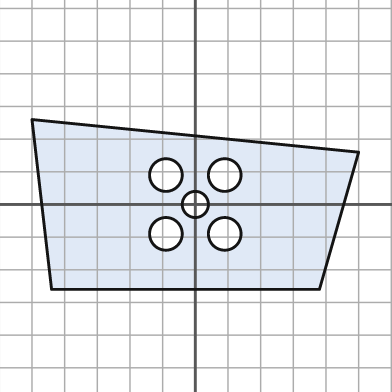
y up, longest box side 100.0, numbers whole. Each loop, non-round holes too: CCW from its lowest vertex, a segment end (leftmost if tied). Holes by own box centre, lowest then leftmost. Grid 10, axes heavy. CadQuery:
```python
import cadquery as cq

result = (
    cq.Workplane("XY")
    .moveTo(-44.0, -26.0)
    .lineTo(38.0, -26.0)
    .lineTo(50.0, 16.0)
    .lineTo(-50.0, 26.0)
    .close()
    .moveTo(-9.0, -9.0)
    .circle(5.0)
    .moveTo(9.0, -9.0)
    .circle(5.0)
    .moveTo(0.0, 0.0)
    .circle(4.0)
    .moveTo(-9.0, 9.0)
    .circle(5.0)
    .moveTo(9.0, 9.0)
    .circle(5.0)
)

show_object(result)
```